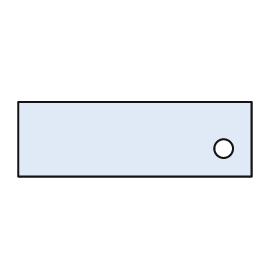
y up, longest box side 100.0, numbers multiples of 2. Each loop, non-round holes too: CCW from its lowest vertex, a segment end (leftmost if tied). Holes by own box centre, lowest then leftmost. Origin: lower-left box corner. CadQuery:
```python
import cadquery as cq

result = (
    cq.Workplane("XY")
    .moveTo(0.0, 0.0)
    .lineTo(100.0, 0.0)
    .lineTo(100.0, 32.0)
    .lineTo(0.0, 32.0)
    .close()
    .moveTo(88.0, 12.0)
    .circle(4.0)
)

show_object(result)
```